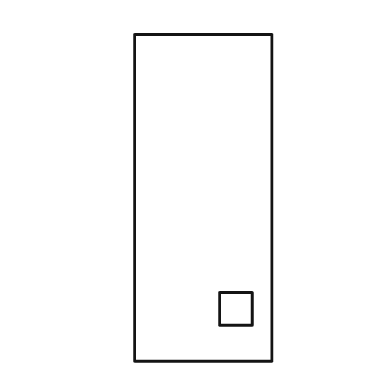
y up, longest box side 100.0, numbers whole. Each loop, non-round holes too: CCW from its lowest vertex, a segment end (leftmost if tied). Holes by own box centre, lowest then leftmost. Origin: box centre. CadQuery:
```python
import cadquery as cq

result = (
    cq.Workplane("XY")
    .moveTo(-21.0, -50.0)
    .lineTo(21.0, -50.0)
    .lineTo(21.0, 50.0)
    .lineTo(-21.0, 50.0)
    .close()
    .moveTo(5.0, -39.0)
    .lineTo(15.0, -39.0)
    .lineTo(15.0, -29.0)
    .lineTo(5.0, -29.0)
    .close()
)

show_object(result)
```